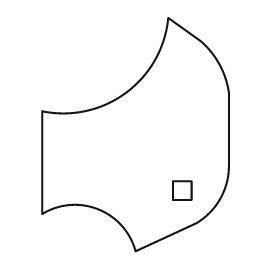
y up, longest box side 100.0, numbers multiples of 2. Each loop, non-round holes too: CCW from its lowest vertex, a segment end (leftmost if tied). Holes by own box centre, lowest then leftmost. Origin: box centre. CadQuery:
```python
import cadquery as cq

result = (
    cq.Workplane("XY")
    .moveTo(0.0, -50.0)
    .lineTo(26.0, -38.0)
    .threePointArc((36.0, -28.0), (40.0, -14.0))
    .lineTo(40.0, 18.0)
    .threePointArc((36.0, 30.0), (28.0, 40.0))
    .lineTo(14.0, 50.0)
    .threePointArc((-4.0, 18.0), (-40.0, 10.0))
    .lineTo(-40.0, -34.0)
    .threePointArc((-16.0, -32.0), (0.0, -50.0))
    .close()
    .moveTo(16.0, -28.0)
    .lineTo(24.0, -28.0)
    .lineTo(24.0, -20.0)
    .lineTo(16.0, -20.0)
    .close()
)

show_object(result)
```